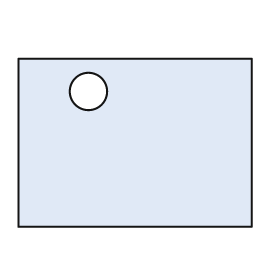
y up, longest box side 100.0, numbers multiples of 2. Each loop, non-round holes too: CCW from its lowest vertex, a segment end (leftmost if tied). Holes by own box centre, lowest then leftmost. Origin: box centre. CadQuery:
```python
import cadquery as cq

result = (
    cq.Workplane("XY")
    .moveTo(-50.0, -36.0)
    .lineTo(50.0, -36.0)
    .lineTo(50.0, 36.0)
    .lineTo(-50.0, 36.0)
    .close()
    .moveTo(-20.0, 22.0)
    .circle(8.0)
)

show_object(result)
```